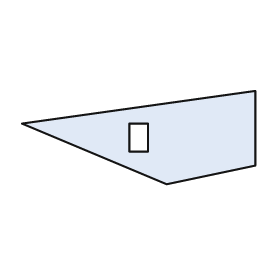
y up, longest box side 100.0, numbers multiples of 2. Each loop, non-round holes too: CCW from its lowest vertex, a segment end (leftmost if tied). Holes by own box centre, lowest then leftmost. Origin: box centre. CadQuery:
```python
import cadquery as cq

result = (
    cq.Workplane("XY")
    .moveTo(12.0, -20.0)
    .lineTo(50.0, -12.0)
    .lineTo(50.0, 20.0)
    .lineTo(-50.0, 6.0)
    .close()
    .moveTo(-4.0, -6.0)
    .lineTo(4.0, -6.0)
    .lineTo(4.0, 6.0)
    .lineTo(-4.0, 6.0)
    .close()
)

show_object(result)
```